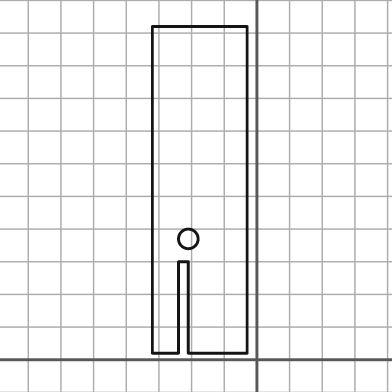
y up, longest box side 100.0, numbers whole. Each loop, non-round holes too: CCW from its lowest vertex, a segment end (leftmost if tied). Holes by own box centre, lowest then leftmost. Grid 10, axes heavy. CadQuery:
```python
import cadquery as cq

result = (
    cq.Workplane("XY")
    .moveTo(-32.0, 2.0)
    .lineTo(-24.0, 2.0)
    .lineTo(-24.0, 30.0)
    .lineTo(-21.0, 30.0)
    .lineTo(-21.0, 2.0)
    .lineTo(-3.0, 2.0)
    .lineTo(-3.0, 102.0)
    .lineTo(-32.0, 102.0)
    .close()
    .moveTo(-21.0, 37.0)
    .circle(3.0)
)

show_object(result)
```